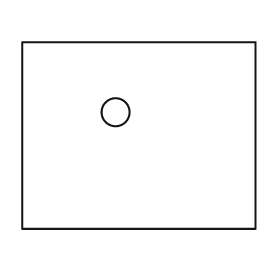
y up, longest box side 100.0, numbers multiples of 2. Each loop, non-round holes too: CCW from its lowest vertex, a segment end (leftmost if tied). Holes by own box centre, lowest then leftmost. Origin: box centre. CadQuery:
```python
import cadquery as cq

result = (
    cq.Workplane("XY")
    .moveTo(-50.0, -40.0)
    .lineTo(50.0, -40.0)
    .lineTo(50.0, 40.0)
    .lineTo(-50.0, 40.0)
    .close()
    .moveTo(-10.0, 10.0)
    .circle(6.0)
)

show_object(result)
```